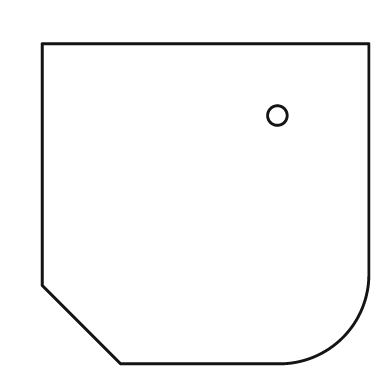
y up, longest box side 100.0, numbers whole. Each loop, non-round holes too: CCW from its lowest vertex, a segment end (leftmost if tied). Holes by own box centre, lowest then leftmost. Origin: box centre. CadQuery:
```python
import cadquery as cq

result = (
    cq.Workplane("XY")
    .moveTo(-26.0, -49.0)
    .lineTo(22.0, -49.0)
    .threePointArc((42.0, -41.0), (50.0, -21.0))
    .lineTo(50.0, 49.0)
    .lineTo(-50.0, 49.0)
    .lineTo(-50.0, -25.0)
    .close()
    .moveTo(22.0, 27.0)
    .circle(3.0)
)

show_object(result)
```